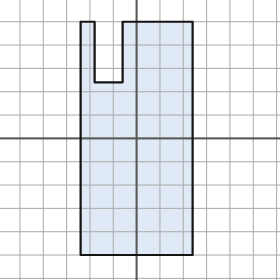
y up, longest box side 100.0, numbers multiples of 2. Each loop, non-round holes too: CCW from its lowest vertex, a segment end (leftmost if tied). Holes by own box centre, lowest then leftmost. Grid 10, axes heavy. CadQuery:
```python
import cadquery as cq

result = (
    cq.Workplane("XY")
    .moveTo(-24.0, -50.0)
    .lineTo(24.0, -50.0)
    .lineTo(24.0, 50.0)
    .lineTo(-6.0, 50.0)
    .lineTo(-6.0, 24.0)
    .lineTo(-18.0, 24.0)
    .lineTo(-18.0, 50.0)
    .lineTo(-24.0, 50.0)
    .close()
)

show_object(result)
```